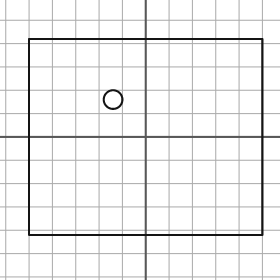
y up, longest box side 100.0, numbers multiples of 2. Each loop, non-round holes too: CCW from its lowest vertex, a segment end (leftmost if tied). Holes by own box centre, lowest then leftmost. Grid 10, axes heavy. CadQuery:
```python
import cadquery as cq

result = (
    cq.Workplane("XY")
    .moveTo(-50.0, -42.0)
    .lineTo(50.0, -42.0)
    .lineTo(50.0, 42.0)
    .lineTo(-50.0, 42.0)
    .close()
    .moveTo(-14.0, 16.0)
    .circle(4.0)
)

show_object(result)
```